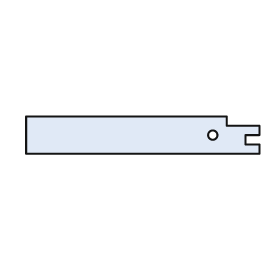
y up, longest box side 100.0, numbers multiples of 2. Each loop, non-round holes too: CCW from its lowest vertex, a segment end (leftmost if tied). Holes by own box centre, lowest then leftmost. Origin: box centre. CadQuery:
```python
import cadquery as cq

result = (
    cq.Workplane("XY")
    .moveTo(-50.0, -8.0)
    .lineTo(50.0, -8.0)
    .lineTo(50.0, -4.0)
    .lineTo(44.0, -4.0)
    .lineTo(44.0, 0.0)
    .lineTo(50.0, 0.0)
    .lineTo(50.0, 4.0)
    .lineTo(36.0, 4.0)
    .lineTo(36.0, 8.0)
    .lineTo(-50.0, 8.0)
    .close()
    .moveTo(30.0, 0.0)
    .circle(2.0)
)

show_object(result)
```